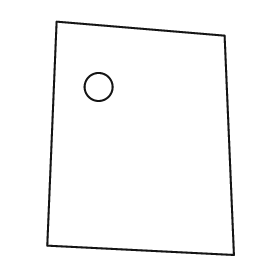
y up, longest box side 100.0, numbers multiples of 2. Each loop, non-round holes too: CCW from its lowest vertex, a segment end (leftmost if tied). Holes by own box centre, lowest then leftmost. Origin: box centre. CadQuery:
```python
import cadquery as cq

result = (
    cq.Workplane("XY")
    .moveTo(40.0, -50.0)
    .lineTo(36.0, 44.0)
    .lineTo(-36.0, 50.0)
    .lineTo(-40.0, -46.0)
    .close()
    .moveTo(-18.0, 22.0)
    .circle(6.0)
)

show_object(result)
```